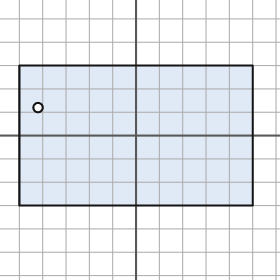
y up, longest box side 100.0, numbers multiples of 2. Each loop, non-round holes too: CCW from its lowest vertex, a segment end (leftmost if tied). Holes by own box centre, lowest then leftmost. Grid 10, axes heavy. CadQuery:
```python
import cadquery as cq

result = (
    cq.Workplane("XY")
    .moveTo(-50.0, -30.0)
    .lineTo(50.0, -30.0)
    .lineTo(50.0, 30.0)
    .lineTo(-50.0, 30.0)
    .close()
    .moveTo(-42.0, 12.0)
    .circle(2.0)
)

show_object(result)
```